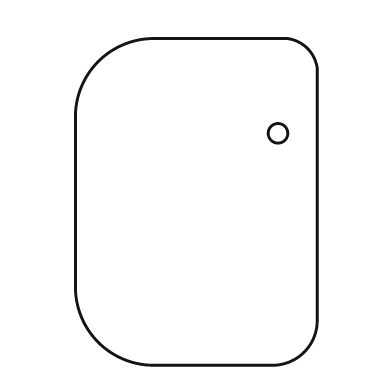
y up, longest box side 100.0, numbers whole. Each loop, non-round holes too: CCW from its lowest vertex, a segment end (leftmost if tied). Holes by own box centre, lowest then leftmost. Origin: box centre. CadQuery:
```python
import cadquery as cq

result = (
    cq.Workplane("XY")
    .moveTo(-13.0, -50.0)
    .lineTo(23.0, -50.0)
    .threePointArc((33.0, -46.0), (37.0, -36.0))
    .lineTo(37.0, 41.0)
    .threePointArc((34.0, 47.0), (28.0, 50.0))
    .lineTo(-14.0, 50.0)
    .threePointArc((-30.0, 43.0), (-37.0, 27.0))
    .lineTo(-37.0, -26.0)
    .threePointArc((-30.0, -43.0), (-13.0, -50.0))
    .close()
    .moveTo(25.0, 21.0)
    .circle(3.0)
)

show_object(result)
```